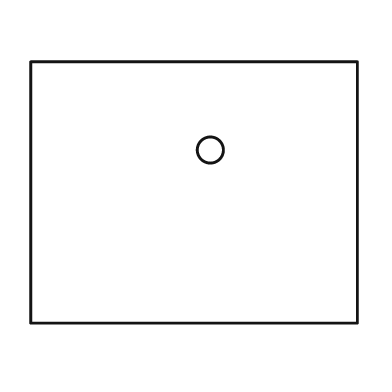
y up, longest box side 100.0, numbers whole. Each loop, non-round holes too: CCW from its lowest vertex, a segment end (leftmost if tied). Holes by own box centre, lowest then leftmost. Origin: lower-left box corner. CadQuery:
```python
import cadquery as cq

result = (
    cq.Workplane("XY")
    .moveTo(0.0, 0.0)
    .lineTo(100.0, 0.0)
    .lineTo(100.0, 80.0)
    .lineTo(0.0, 80.0)
    .close()
    .moveTo(55.0, 53.0)
    .circle(4.0)
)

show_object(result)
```